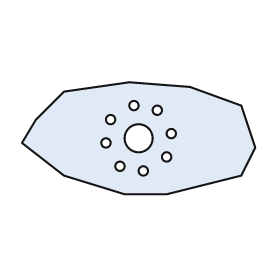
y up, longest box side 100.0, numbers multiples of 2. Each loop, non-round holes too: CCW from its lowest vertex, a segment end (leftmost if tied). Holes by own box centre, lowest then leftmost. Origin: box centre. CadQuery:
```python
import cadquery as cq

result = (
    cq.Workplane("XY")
    .moveTo(-6.0, -24.0)
    .lineTo(12.0, -24.0)
    .lineTo(44.0, -16.0)
    .lineTo(50.0, -4.0)
    .lineTo(44.0, 14.0)
    .lineTo(22.0, 22.0)
    .lineTo(-4.0, 24.0)
    .lineTo(-32.0, 20.0)
    .lineTo(-44.0, 8.0)
    .lineTo(-50.0, -2.0)
    .lineTo(-32.0, -16.0)
    .close()
    .moveTo(2.0, -14.0)
    .circle(2.0)
    .moveTo(-8.0, -12.0)
    .circle(2.0)
    .moveTo(12.0, -8.0)
    .circle(2.0)
    .moveTo(-14.0, -2.0)
    .circle(2.0)
    .moveTo(0.0, 0.0)
    .circle(6.0)
    .moveTo(14.0, 2.0)
    .circle(2.0)
    .moveTo(-12.0, 8.0)
    .circle(2.0)
    .moveTo(8.0, 12.0)
    .circle(2.0)
    .moveTo(-2.0, 14.0)
    .circle(2.0)
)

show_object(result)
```